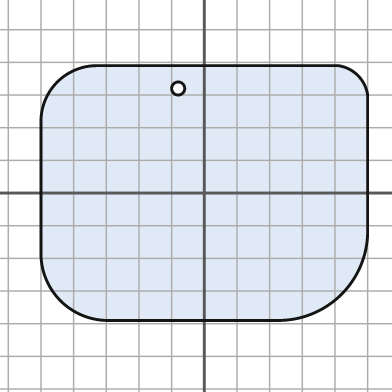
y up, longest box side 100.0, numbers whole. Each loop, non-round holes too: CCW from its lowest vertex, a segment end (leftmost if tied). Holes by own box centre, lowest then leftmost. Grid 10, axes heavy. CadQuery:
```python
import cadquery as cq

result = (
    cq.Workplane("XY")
    .moveTo(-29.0, -39.0)
    .lineTo(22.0, -39.0)
    .threePointArc((42.0, -31.0), (50.0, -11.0))
    .lineTo(50.0, 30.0)
    .threePointArc((47.0, 36.0), (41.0, 39.0))
    .lineTo(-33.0, 39.0)
    .threePointArc((-45.0, 34.0), (-50.0, 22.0))
    .lineTo(-50.0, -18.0)
    .threePointArc((-44.0, -33.0), (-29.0, -39.0))
    .close()
    .moveTo(-8.0, 32.0)
    .circle(2.0)
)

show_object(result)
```